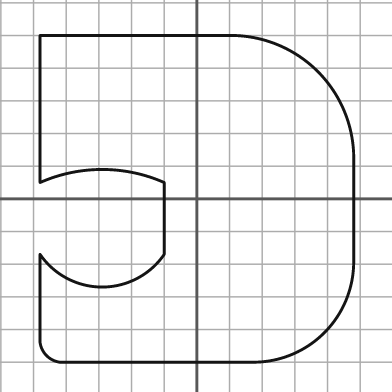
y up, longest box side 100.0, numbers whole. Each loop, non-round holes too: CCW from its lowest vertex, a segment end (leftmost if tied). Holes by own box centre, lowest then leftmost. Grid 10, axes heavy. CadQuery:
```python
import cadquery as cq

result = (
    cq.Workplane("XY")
    .moveTo(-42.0, -50.0)
    .lineTo(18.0, -50.0)
    .threePointArc((39.0, -41.0), (48.0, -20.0))
    .lineTo(48.0, 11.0)
    .threePointArc((37.0, 39.0), (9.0, 50.0))
    .lineTo(-48.0, 50.0)
    .lineTo(-48.0, 5.0)
    .threePointArc((-29.0, 9.0), (-10.0, 5.0))
    .lineTo(-10.0, -17.0)
    .threePointArc((-29.0, -27.0), (-48.0, -17.0))
    .lineTo(-48.0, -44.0)
    .threePointArc((-46.0, -48.0), (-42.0, -50.0))
    .close()
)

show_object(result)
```